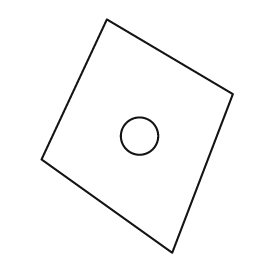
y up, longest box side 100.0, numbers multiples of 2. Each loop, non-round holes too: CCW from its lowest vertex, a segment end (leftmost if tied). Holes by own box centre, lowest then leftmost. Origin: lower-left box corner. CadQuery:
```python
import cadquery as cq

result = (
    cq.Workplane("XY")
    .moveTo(56.0, 0.0)
    .lineTo(82.0, 68.0)
    .lineTo(28.0, 100.0)
    .lineTo(0.0, 40.0)
    .close()
    .moveTo(42.0, 50.0)
    .circle(8.0)
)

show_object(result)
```